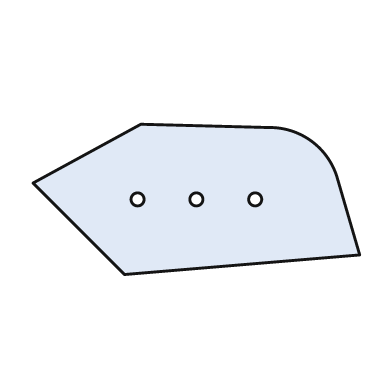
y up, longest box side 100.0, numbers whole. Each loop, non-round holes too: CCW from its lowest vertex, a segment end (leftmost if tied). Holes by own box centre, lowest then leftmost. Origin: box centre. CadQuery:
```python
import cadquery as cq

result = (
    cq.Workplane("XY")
    .moveTo(-22.0, -23.0)
    .lineTo(50.0, -17.0)
    .lineTo(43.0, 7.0)
    .threePointArc((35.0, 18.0), (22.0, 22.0))
    .lineTo(-17.0, 23.0)
    .lineTo(-50.0, 5.0)
    .close()
    .moveTo(-18.0, 0.0)
    .circle(2.0)
    .moveTo(0.0, 0.0)
    .circle(2.0)
    .moveTo(18.0, 0.0)
    .circle(2.0)
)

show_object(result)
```